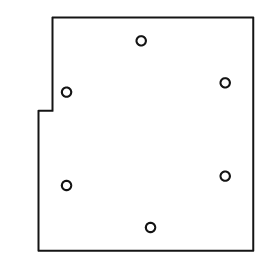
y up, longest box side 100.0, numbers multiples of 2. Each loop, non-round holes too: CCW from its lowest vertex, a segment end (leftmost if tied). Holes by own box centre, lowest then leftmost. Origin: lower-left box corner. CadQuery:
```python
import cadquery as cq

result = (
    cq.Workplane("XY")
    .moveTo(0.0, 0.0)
    .lineTo(92.0, 0.0)
    .lineTo(92.0, 100.0)
    .lineTo(6.0, 100.0)
    .lineTo(6.0, 60.0)
    .lineTo(0.0, 60.0)
    .close()
    .moveTo(48.0, 10.0)
    .circle(2.0)
    .moveTo(12.0, 28.0)
    .circle(2.0)
    .moveTo(80.0, 32.0)
    .circle(2.0)
    .moveTo(12.0, 68.0)
    .circle(2.0)
    .moveTo(80.0, 72.0)
    .circle(2.0)
    .moveTo(44.0, 90.0)
    .circle(2.0)
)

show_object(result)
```